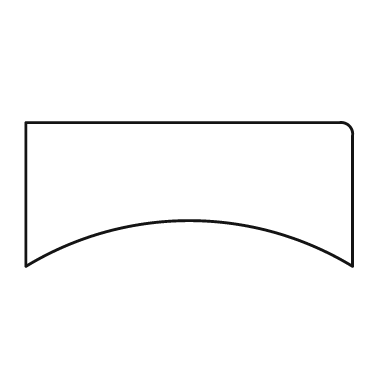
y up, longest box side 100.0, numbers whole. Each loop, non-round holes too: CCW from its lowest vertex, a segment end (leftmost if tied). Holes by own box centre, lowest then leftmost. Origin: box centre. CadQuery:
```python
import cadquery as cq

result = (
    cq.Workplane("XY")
    .moveTo(-50.0, -22.0)
    .threePointArc((0.0, -8.0), (50.0, -22.0))
    .lineTo(50.0, 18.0)
    .threePointArc((49.0, 21.0), (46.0, 22.0))
    .lineTo(-50.0, 22.0)
    .close()
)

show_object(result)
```